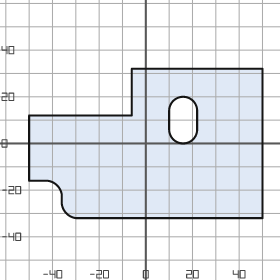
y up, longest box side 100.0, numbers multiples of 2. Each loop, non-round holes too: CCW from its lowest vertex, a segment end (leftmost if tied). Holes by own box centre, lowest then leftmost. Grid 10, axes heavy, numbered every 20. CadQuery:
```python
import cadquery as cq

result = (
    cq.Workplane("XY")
    .moveTo(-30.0, -32.0)
    .lineTo(50.0, -32.0)
    .lineTo(50.0, 32.0)
    .lineTo(-6.0, 32.0)
    .lineTo(-6.0, 12.0)
    .lineTo(-50.0, 12.0)
    .lineTo(-50.0, -16.0)
    .lineTo(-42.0, -16.0)
    .threePointArc((-38.0, -18.0), (-36.0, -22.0))
    .lineTo(-36.0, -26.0)
    .threePointArc((-34.0, -30.0), (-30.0, -32.0))
    .close()
    .moveTo(10.0, 6.0)
    .threePointArc((16.0, 0.0), (22.0, 6.0))
    .lineTo(22.0, 14.0)
    .threePointArc((16.0, 20.0), (10.0, 14.0))
    .close()
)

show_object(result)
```